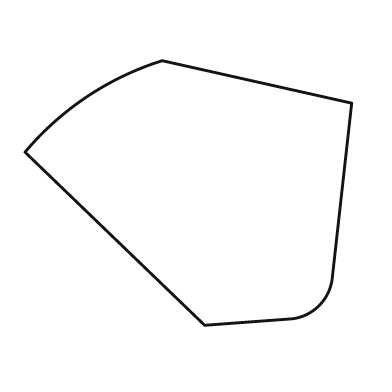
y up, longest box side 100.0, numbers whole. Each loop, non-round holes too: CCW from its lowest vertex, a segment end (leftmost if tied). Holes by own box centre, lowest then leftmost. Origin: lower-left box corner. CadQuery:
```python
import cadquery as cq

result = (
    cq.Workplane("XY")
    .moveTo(55.0, 0.0)
    .lineTo(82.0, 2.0)
    .threePointArc((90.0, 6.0), (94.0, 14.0))
    .lineTo(100.0, 68.0)
    .lineTo(42.0, 81.0)
    .threePointArc((19.0, 70.0), (0.0, 53.0))
    .close()
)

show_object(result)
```